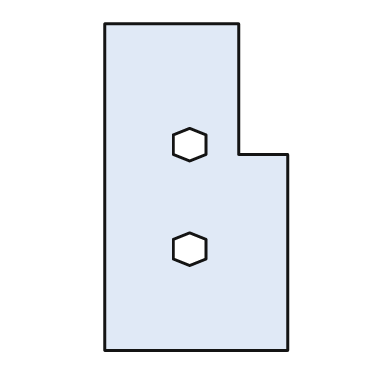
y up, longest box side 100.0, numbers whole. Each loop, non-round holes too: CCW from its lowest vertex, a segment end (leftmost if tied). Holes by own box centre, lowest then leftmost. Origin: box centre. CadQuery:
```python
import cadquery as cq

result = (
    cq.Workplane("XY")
    .moveTo(-28.0, -50.0)
    .lineTo(28.0, -50.0)
    .lineTo(28.0, 10.0)
    .lineTo(13.0, 10.0)
    .lineTo(13.0, 50.0)
    .lineTo(-28.0, 50.0)
    .close()
    .moveTo(-2.0, -24.0)
    .lineTo(3.0, -22.0)
    .lineTo(3.0, -16.0)
    .lineTo(-2.0, -14.0)
    .lineTo(-7.0, -16.0)
    .lineTo(-7.0, -22.0)
    .close()
    .moveTo(-2.0, 8.0)
    .lineTo(3.0, 10.0)
    .lineTo(3.0, 16.0)
    .lineTo(-2.0, 18.0)
    .lineTo(-7.0, 16.0)
    .lineTo(-7.0, 10.0)
    .close()
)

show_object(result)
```